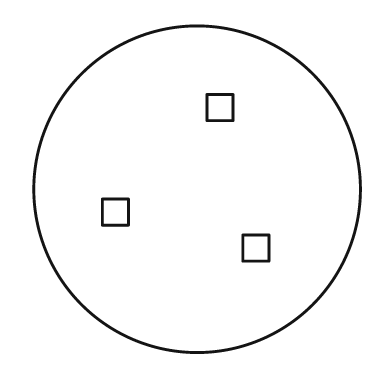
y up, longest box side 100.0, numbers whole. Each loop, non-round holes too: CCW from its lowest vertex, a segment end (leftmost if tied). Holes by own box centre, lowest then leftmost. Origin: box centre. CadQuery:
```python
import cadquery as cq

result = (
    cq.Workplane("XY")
    .moveTo(0.0, 0.0)
    .circle(50.0)
    .moveTo(14.0, -22.0)
    .lineTo(22.0, -22.0)
    .lineTo(22.0, -14.0)
    .lineTo(14.0, -14.0)
    .close()
    .moveTo(-29.0, -11.0)
    .lineTo(-21.0, -11.0)
    .lineTo(-21.0, -3.0)
    .lineTo(-29.0, -3.0)
    .close()
    .moveTo(3.0, 21.0)
    .lineTo(11.0, 21.0)
    .lineTo(11.0, 29.0)
    .lineTo(3.0, 29.0)
    .close()
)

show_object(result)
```